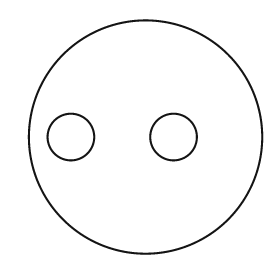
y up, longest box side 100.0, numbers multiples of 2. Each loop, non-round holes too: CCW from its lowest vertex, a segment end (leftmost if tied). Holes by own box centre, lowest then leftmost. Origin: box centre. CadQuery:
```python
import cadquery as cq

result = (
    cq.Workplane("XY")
    .moveTo(0.0, 0.0)
    .circle(50.0)
    .moveTo(-32.0, 0.0)
    .circle(10.0)
    .moveTo(12.0, 0.0)
    .circle(10.0)
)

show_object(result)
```